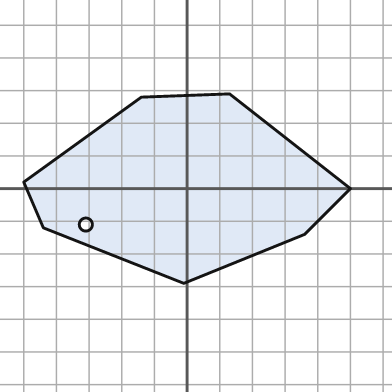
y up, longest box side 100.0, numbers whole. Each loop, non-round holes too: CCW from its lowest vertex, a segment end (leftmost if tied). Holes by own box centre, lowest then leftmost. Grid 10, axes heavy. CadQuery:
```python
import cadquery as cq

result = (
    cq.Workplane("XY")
    .moveTo(-1.0, -29.0)
    .lineTo(36.0, -14.0)
    .lineTo(50.0, 0.0)
    .lineTo(13.0, 29.0)
    .lineTo(-14.0, 28.0)
    .lineTo(-50.0, 2.0)
    .lineTo(-44.0, -12.0)
    .close()
    .moveTo(-31.0, -11.0)
    .circle(2.0)
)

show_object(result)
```